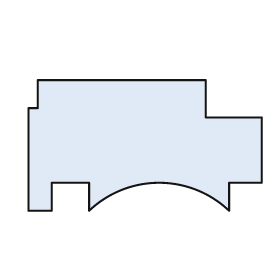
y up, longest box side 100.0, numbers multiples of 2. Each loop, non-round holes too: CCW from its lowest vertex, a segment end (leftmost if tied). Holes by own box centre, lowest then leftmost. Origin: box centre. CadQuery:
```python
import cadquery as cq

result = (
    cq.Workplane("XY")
    .moveTo(-50.0, -28.0)
    .lineTo(-40.0, -28.0)
    .lineTo(-40.0, -16.0)
    .lineTo(-24.0, -16.0)
    .lineTo(-24.0, -28.0)
    .threePointArc((6.0, -16.0), (36.0, -28.0))
    .lineTo(36.0, -16.0)
    .lineTo(50.0, -16.0)
    .lineTo(50.0, 12.0)
    .lineTo(26.0, 12.0)
    .lineTo(26.0, 28.0)
    .lineTo(-46.0, 28.0)
    .lineTo(-46.0, 16.0)
    .lineTo(-50.0, 16.0)
    .close()
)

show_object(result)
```